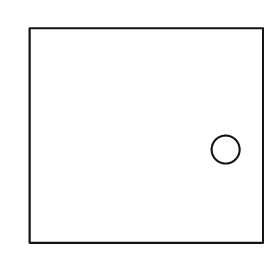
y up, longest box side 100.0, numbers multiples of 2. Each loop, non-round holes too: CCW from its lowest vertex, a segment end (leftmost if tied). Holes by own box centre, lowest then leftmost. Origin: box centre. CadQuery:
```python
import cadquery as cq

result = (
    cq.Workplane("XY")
    .moveTo(-50.0, -46.0)
    .lineTo(50.0, -46.0)
    .lineTo(50.0, 46.0)
    .lineTo(-50.0, 46.0)
    .close()
    .moveTo(34.0, -6.0)
    .circle(6.0)
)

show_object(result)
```